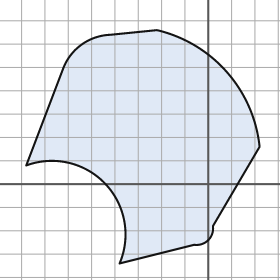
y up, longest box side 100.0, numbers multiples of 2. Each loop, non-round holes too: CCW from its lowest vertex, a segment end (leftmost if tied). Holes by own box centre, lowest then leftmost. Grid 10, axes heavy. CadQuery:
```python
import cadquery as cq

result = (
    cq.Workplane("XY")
    .moveTo(-38.0, -34.0)
    .lineTo(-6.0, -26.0)
    .threePointArc((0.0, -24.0), (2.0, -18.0))
    .lineTo(22.0, 16.0)
    .threePointArc((8.0, 48.0), (-22.0, 66.0))
    .lineTo(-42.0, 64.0)
    .threePointArc((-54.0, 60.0), (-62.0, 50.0))
    .lineTo(-78.0, 8.0)
    .threePointArc((-44.0, 0.0), (-38.0, -34.0))
    .close()
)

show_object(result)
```